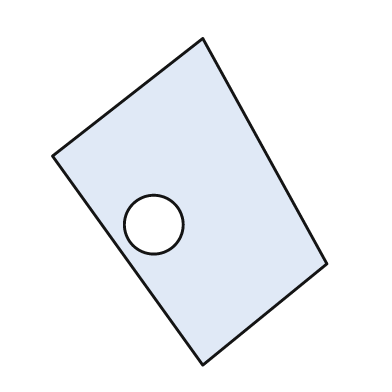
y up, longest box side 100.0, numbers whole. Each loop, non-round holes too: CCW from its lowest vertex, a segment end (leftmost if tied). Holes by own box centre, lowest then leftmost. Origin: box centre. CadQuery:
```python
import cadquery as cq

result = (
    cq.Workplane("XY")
    .moveTo(4.0, -50.0)
    .lineTo(42.0, -19.0)
    .lineTo(4.0, 50.0)
    .lineTo(-42.0, 14.0)
    .close()
    .moveTo(-11.0, -7.0)
    .circle(9.0)
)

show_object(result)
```